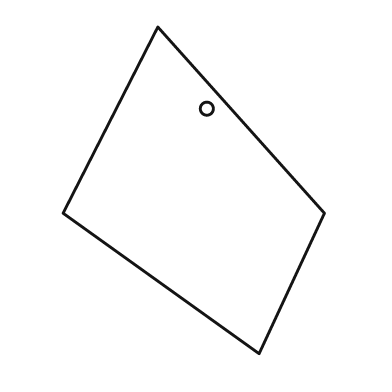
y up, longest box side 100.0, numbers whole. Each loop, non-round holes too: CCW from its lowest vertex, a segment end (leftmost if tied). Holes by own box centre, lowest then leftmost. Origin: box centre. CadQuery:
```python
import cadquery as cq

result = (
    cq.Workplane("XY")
    .moveTo(20.0, -50.0)
    .lineTo(40.0, -7.0)
    .lineTo(-11.0, 50.0)
    .lineTo(-40.0, -7.0)
    .close()
    .moveTo(4.0, 25.0)
    .circle(2.0)
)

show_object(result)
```